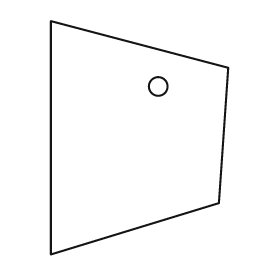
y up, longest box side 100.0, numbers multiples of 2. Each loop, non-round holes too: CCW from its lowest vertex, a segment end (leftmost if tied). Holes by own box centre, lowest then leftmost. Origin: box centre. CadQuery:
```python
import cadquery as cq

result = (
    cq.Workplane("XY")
    .moveTo(-38.0, -50.0)
    .lineTo(34.0, -28.0)
    .lineTo(38.0, 30.0)
    .lineTo(-38.0, 50.0)
    .close()
    .moveTo(8.0, 22.0)
    .circle(4.0)
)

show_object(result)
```